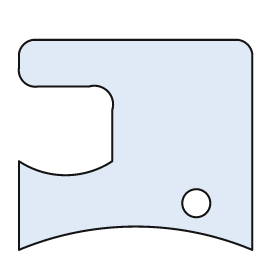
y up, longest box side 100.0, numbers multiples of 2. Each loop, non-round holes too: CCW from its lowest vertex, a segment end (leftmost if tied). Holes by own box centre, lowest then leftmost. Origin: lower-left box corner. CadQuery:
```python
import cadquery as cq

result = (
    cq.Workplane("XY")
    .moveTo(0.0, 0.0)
    .threePointArc((50.0, 10.0), (100.0, 0.0))
    .lineTo(100.0, 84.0)
    .threePointArc((98.0, 88.0), (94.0, 90.0))
    .lineTo(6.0, 90.0)
    .threePointArc((2.0, 88.0), (0.0, 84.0))
    .lineTo(0.0, 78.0)
    .threePointArc((2.0, 72.0), (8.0, 70.0))
    .lineTo(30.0, 70.0)
    .threePointArc((38.0, 68.0), (40.0, 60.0))
    .lineTo(40.0, 38.0)
    .threePointArc((20.0, 32.0), (0.0, 38.0))
    .close()
    .moveTo(76.0, 20.0)
    .circle(6.0)
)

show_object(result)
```